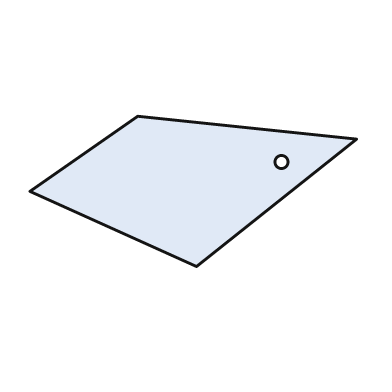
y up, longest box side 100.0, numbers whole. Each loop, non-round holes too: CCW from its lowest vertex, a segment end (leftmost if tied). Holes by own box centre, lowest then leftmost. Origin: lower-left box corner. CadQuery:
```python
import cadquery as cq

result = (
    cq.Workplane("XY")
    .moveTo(51.0, 0.0)
    .lineTo(100.0, 39.0)
    .lineTo(33.0, 46.0)
    .lineTo(0.0, 23.0)
    .close()
    .moveTo(77.0, 32.0)
    .circle(2.0)
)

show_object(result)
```